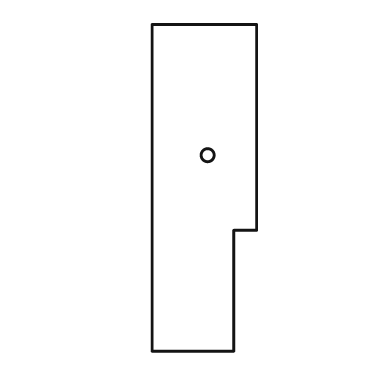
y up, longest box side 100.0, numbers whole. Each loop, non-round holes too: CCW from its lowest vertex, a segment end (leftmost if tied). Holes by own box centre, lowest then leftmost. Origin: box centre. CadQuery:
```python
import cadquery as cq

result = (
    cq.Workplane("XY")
    .moveTo(-16.0, -50.0)
    .lineTo(9.0, -50.0)
    .lineTo(9.0, -13.0)
    .lineTo(16.0, -13.0)
    .lineTo(16.0, 50.0)
    .lineTo(-16.0, 50.0)
    .close()
    .moveTo(1.0, 10.0)
    .circle(2.0)
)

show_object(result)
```